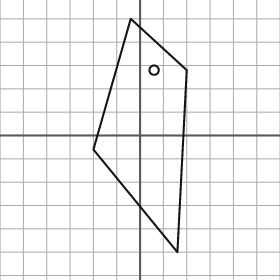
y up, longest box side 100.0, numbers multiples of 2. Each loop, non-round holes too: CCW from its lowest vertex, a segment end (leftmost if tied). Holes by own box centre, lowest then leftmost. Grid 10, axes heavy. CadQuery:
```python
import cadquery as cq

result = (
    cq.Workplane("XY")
    .moveTo(16.0, -50.0)
    .lineTo(20.0, 28.0)
    .lineTo(-4.0, 50.0)
    .lineTo(-20.0, -6.0)
    .close()
    .moveTo(6.0, 28.0)
    .circle(2.0)
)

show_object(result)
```